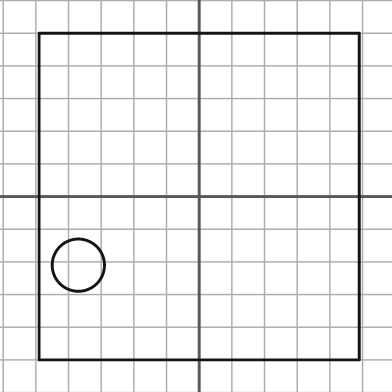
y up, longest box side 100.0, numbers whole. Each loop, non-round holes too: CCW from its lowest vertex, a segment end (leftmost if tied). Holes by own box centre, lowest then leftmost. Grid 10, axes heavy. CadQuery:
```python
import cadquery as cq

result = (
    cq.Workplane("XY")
    .moveTo(-49.0, -50.0)
    .lineTo(49.0, -50.0)
    .lineTo(49.0, 50.0)
    .lineTo(-49.0, 50.0)
    .close()
    .moveTo(-37.0, -21.0)
    .circle(8.0)
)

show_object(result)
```